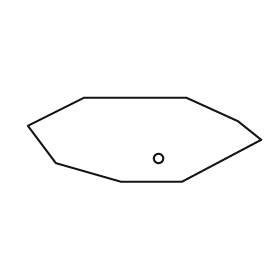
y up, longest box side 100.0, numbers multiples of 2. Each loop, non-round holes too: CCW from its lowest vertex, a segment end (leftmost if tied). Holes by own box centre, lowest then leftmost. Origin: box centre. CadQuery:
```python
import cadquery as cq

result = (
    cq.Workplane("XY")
    .moveTo(-10.0, -18.0)
    .lineTo(16.0, -18.0)
    .lineTo(50.0, 0.0)
    .lineTo(40.0, 8.0)
    .lineTo(18.0, 18.0)
    .lineTo(-26.0, 18.0)
    .lineTo(-50.0, 6.0)
    .lineTo(-38.0, -10.0)
    .close()
    .moveTo(6.0, -8.0)
    .circle(2.0)
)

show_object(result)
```